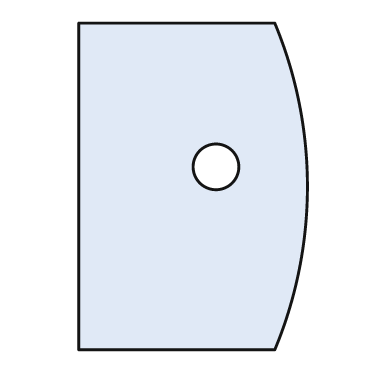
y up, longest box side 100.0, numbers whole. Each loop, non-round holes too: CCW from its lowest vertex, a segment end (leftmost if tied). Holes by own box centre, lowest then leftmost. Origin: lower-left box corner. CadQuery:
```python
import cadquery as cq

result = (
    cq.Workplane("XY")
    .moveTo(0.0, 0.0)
    .lineTo(60.0, 0.0)
    .threePointArc((70.0, 50.0), (60.0, 100.0))
    .lineTo(0.0, 100.0)
    .close()
    .moveTo(42.0, 56.0)
    .circle(7.0)
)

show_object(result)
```